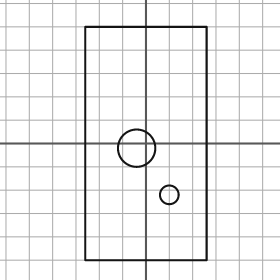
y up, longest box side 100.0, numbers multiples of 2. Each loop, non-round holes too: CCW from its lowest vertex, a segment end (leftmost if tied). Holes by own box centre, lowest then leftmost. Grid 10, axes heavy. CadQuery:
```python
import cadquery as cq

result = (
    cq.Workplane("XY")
    .moveTo(-26.0, -50.0)
    .lineTo(26.0, -50.0)
    .lineTo(26.0, 50.0)
    .lineTo(-26.0, 50.0)
    .close()
    .moveTo(10.0, -22.0)
    .circle(4.0)
    .moveTo(-4.0, -2.0)
    .circle(8.0)
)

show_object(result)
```